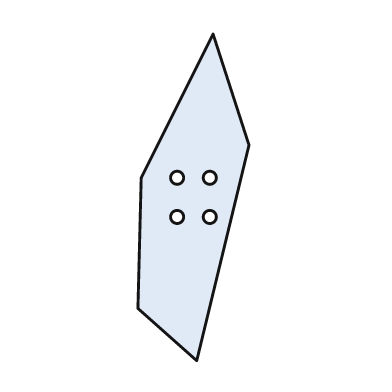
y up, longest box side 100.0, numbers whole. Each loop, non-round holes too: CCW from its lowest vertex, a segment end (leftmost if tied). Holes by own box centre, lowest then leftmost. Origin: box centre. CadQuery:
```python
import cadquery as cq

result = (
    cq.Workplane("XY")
    .moveTo(1.0, -50.0)
    .lineTo(17.0, 16.0)
    .lineTo(6.0, 50.0)
    .lineTo(-16.0, 6.0)
    .lineTo(-17.0, -34.0)
    .close()
    .moveTo(-5.0, -6.0)
    .circle(2.0)
    .moveTo(5.0, -6.0)
    .circle(2.0)
    .moveTo(-5.0, 6.0)
    .circle(2.0)
    .moveTo(5.0, 6.0)
    .circle(2.0)
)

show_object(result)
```